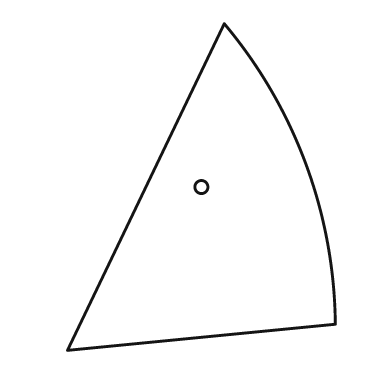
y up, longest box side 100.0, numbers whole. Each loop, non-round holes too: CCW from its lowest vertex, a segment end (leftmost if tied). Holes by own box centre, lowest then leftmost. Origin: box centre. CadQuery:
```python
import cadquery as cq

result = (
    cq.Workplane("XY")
    .moveTo(-41.0, -50.0)
    .lineTo(41.0, -42.0)
    .threePointArc((32.0, 7.0), (7.0, 50.0))
    .close()
    .moveTo(0.0, 0.0)
    .circle(2.0)
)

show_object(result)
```